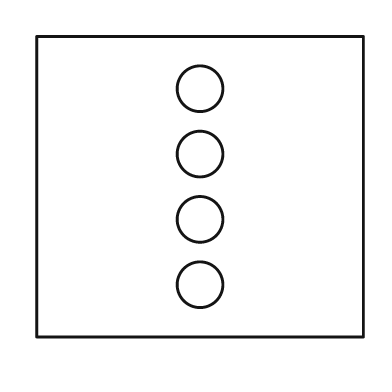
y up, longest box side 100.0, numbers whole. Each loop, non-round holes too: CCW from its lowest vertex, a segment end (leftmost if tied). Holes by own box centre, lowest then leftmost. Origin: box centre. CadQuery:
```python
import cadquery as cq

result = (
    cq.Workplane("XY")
    .moveTo(-50.0, -46.0)
    .lineTo(50.0, -46.0)
    .lineTo(50.0, 46.0)
    .lineTo(-50.0, 46.0)
    .close()
    .moveTo(0.0, -30.0)
    .circle(7.0)
    .moveTo(0.0, -10.0)
    .circle(7.0)
    .moveTo(0.0, 10.0)
    .circle(7.0)
    .moveTo(0.0, 30.0)
    .circle(7.0)
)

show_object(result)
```